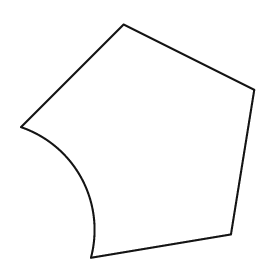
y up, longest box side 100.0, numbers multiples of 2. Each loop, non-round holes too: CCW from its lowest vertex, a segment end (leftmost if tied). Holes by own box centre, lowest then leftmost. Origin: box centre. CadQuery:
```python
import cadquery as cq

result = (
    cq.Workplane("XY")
    .moveTo(-20.0, -50.0)
    .lineTo(40.0, -40.0)
    .lineTo(50.0, 22.0)
    .lineTo(-6.0, 50.0)
    .lineTo(-50.0, 6.0)
    .threePointArc((-24.0, -16.0), (-20.0, -50.0))
    .close()
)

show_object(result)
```